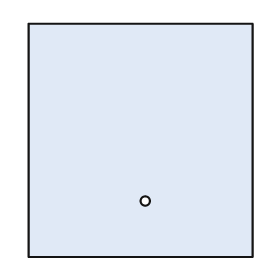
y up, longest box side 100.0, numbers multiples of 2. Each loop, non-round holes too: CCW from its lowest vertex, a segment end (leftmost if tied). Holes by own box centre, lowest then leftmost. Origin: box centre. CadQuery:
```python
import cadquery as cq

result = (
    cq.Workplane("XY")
    .moveTo(-48.0, -50.0)
    .lineTo(48.0, -50.0)
    .lineTo(48.0, 50.0)
    .lineTo(-48.0, 50.0)
    .close()
    .moveTo(2.0, -26.0)
    .circle(2.0)
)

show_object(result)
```